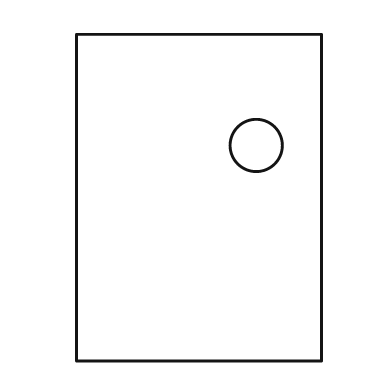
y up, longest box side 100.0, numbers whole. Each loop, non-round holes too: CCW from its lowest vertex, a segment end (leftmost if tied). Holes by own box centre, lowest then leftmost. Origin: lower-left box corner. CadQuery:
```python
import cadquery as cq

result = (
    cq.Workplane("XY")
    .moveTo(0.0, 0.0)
    .lineTo(75.0, 0.0)
    .lineTo(75.0, 100.0)
    .lineTo(0.0, 100.0)
    .close()
    .moveTo(55.0, 66.0)
    .circle(8.0)
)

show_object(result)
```